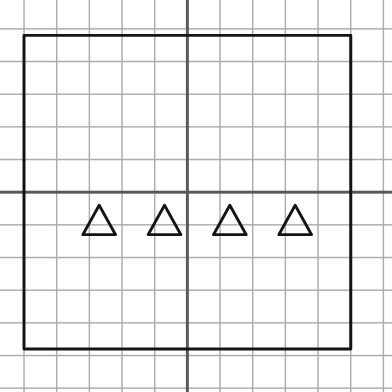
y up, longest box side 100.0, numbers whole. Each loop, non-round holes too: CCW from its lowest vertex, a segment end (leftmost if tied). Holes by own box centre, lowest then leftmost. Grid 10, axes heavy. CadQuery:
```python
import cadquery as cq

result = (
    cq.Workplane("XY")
    .moveTo(-50.0, -48.0)
    .lineTo(50.0, -48.0)
    .lineTo(50.0, 48.0)
    .lineTo(-50.0, 48.0)
    .close()
    .moveTo(-32.0, -13.0)
    .lineTo(-22.0, -13.0)
    .lineTo(-27.0, -4.0)
    .close()
    .moveTo(-12.0, -13.0)
    .lineTo(-2.0, -13.0)
    .lineTo(-7.0, -4.0)
    .close()
    .moveTo(8.0, -13.0)
    .lineTo(18.0, -13.0)
    .lineTo(13.0, -4.0)
    .close()
    .moveTo(28.0, -13.0)
    .lineTo(38.0, -13.0)
    .lineTo(33.0, -4.0)
    .close()
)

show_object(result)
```